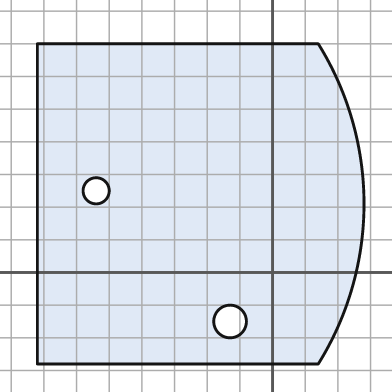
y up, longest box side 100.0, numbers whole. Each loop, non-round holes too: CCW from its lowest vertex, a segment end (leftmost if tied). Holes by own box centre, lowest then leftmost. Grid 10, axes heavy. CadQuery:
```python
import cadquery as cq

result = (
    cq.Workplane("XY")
    .moveTo(-72.0, -28.0)
    .lineTo(14.0, -28.0)
    .threePointArc((28.0, 21.0), (14.0, 70.0))
    .lineTo(-72.0, 70.0)
    .close()
    .moveTo(-13.0, -15.0)
    .circle(5.0)
    .moveTo(-54.0, 25.0)
    .circle(4.0)
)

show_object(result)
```